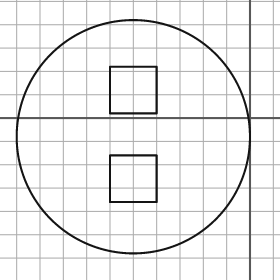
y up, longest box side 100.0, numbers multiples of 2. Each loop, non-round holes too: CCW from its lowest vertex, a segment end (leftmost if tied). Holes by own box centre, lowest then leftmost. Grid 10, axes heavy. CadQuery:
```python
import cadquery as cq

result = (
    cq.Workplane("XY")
    .moveTo(-50.0, -8.0)
    .circle(50.0)
    .moveTo(-60.0, -36.0)
    .lineTo(-40.0, -36.0)
    .lineTo(-40.0, -16.0)
    .lineTo(-60.0, -16.0)
    .close()
    .moveTo(-60.0, 2.0)
    .lineTo(-40.0, 2.0)
    .lineTo(-40.0, 22.0)
    .lineTo(-60.0, 22.0)
    .close()
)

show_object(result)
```